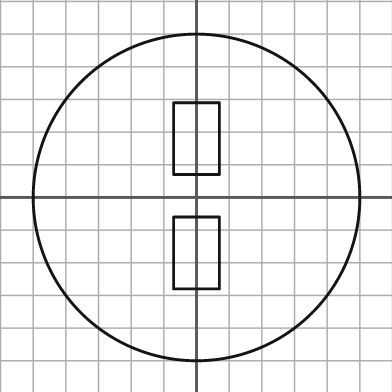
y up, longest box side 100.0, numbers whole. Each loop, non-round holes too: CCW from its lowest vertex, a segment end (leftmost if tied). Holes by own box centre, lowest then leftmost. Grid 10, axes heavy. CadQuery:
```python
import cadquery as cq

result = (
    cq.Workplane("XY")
    .moveTo(0.0, 0.0)
    .circle(50.0)
    .moveTo(-7.0, -28.0)
    .lineTo(7.0, -28.0)
    .lineTo(7.0, -6.0)
    .lineTo(-7.0, -6.0)
    .close()
    .moveTo(-7.0, 7.0)
    .lineTo(7.0, 7.0)
    .lineTo(7.0, 29.0)
    .lineTo(-7.0, 29.0)
    .close()
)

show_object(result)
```